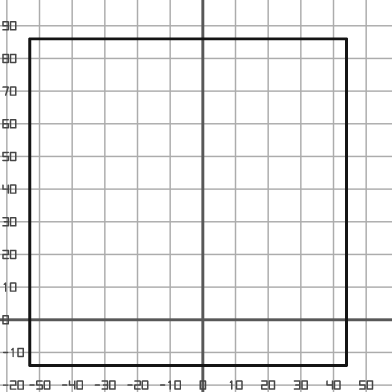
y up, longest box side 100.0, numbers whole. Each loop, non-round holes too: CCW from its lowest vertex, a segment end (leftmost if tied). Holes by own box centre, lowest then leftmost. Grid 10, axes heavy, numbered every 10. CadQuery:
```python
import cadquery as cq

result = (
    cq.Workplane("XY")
    .moveTo(-53.0, -14.0)
    .lineTo(44.0, -14.0)
    .lineTo(44.0, 86.0)
    .lineTo(-53.0, 86.0)
    .close()
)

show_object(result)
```